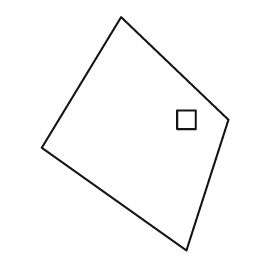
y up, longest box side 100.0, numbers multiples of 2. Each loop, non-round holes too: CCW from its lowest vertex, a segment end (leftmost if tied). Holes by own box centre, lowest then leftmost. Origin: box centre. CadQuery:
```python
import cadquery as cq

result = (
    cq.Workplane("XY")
    .moveTo(22.0, -50.0)
    .lineTo(40.0, 6.0)
    .lineTo(-6.0, 50.0)
    .lineTo(-40.0, -6.0)
    .close()
    .moveTo(18.0, 2.0)
    .lineTo(26.0, 2.0)
    .lineTo(26.0, 10.0)
    .lineTo(18.0, 10.0)
    .close()
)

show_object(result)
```